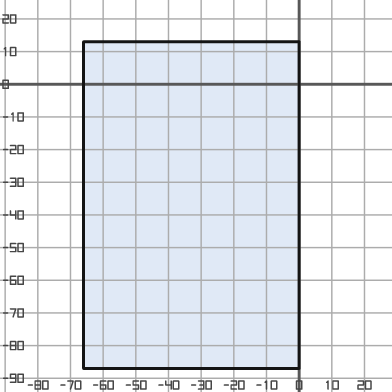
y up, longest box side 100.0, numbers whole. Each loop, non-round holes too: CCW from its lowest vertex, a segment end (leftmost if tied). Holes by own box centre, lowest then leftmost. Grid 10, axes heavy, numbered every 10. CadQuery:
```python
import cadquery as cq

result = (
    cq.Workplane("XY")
    .moveTo(-66.0, -87.0)
    .lineTo(0.0, -87.0)
    .lineTo(0.0, 13.0)
    .lineTo(-66.0, 13.0)
    .close()
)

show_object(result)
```